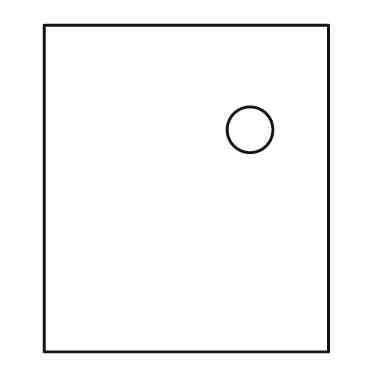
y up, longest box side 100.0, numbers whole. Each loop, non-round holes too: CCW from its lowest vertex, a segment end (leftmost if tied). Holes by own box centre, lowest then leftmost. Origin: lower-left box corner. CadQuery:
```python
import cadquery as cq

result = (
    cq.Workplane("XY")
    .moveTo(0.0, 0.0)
    .lineTo(87.0, 0.0)
    .lineTo(87.0, 100.0)
    .lineTo(0.0, 100.0)
    .close()
    .moveTo(63.0, 68.0)
    .circle(7.0)
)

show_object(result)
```